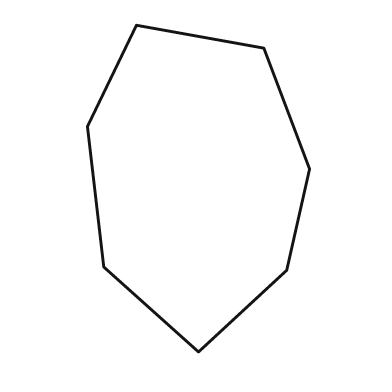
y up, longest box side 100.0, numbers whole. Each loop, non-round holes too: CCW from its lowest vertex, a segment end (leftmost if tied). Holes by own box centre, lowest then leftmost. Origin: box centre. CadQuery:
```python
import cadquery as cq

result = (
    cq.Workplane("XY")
    .moveTo(0.0, -50.0)
    .lineTo(27.0, -25.0)
    .lineTo(34.0, 6.0)
    .lineTo(20.0, 43.0)
    .lineTo(-19.0, 50.0)
    .lineTo(-34.0, 19.0)
    .lineTo(-29.0, -24.0)
    .close()
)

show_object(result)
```